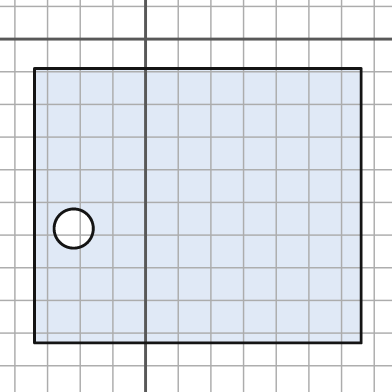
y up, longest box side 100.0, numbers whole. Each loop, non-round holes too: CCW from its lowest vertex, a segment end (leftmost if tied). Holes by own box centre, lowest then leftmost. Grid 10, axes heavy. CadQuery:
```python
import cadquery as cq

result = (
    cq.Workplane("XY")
    .moveTo(-34.0, -93.0)
    .lineTo(66.0, -93.0)
    .lineTo(66.0, -9.0)
    .lineTo(-34.0, -9.0)
    .close()
    .moveTo(-22.0, -58.0)
    .circle(6.0)
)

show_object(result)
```